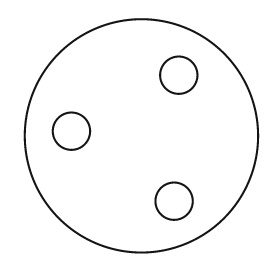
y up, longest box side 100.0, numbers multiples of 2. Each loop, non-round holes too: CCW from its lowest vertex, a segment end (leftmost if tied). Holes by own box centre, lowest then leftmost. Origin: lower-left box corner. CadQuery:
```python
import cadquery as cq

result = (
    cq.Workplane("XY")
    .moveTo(50.0, 50.0)
    .circle(50.0)
    .moveTo(64.0, 22.0)
    .circle(8.0)
    .moveTo(20.0, 52.0)
    .circle(8.0)
    .moveTo(66.0, 76.0)
    .circle(8.0)
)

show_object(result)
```